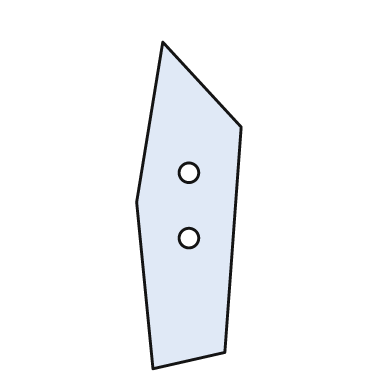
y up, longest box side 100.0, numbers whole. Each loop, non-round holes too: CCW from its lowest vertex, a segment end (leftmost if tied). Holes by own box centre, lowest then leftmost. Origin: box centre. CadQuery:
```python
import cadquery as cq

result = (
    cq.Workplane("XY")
    .moveTo(-11.0, -50.0)
    .lineTo(11.0, -45.0)
    .lineTo(16.0, 24.0)
    .lineTo(-8.0, 50.0)
    .lineTo(-16.0, 1.0)
    .close()
    .moveTo(0.0, -10.0)
    .circle(3.0)
    .moveTo(0.0, 10.0)
    .circle(3.0)
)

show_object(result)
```